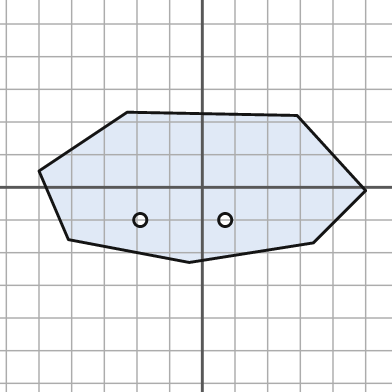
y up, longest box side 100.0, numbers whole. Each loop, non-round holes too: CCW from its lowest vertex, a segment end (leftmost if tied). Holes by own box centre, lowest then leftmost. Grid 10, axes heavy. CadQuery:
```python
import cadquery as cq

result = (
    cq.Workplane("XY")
    .moveTo(-4.0, -23.0)
    .lineTo(34.0, -17.0)
    .lineTo(50.0, -1.0)
    .lineTo(29.0, 22.0)
    .lineTo(-23.0, 23.0)
    .lineTo(-50.0, 5.0)
    .lineTo(-41.0, -16.0)
    .close()
    .moveTo(-19.0, -10.0)
    .circle(2.0)
    .moveTo(7.0, -10.0)
    .circle(2.0)
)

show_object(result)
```